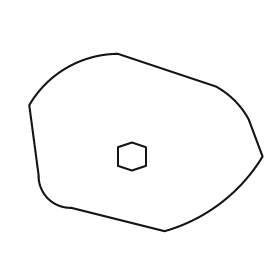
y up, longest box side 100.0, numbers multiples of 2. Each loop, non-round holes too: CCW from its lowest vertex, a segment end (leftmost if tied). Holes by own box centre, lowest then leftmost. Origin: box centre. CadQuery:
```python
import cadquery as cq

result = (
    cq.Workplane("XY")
    .moveTo(8.0, -38.0)
    .threePointArc((32.0, -26.0), (50.0, -6.0))
    .lineTo(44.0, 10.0)
    .threePointArc((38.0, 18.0), (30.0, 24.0))
    .lineTo(-12.0, 38.0)
    .threePointArc((-34.0, 32.0), (-50.0, 16.0))
    .lineTo(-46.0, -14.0)
    .threePointArc((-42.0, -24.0), (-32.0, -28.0))
    .close()
    .moveTo(-6.0, -12.0)
    .lineTo(0.0, -10.0)
    .lineTo(0.0, -2.0)
    .lineTo(-6.0, 0.0)
    .lineTo(-12.0, -2.0)
    .lineTo(-12.0, -10.0)
    .close()
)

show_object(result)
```